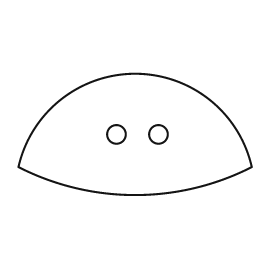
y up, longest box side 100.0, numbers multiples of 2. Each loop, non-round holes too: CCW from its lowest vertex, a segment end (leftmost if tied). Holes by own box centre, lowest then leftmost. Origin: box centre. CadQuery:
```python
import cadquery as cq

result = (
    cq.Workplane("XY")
    .moveTo(-50.0, -14.0)
    .threePointArc((0.0, -26.0), (50.0, -14.0))
    .threePointArc((0.0, 26.0), (-50.0, -14.0))
    .close()
    .moveTo(-8.0, 0.0)
    .circle(4.0)
    .moveTo(10.0, 0.0)
    .circle(4.0)
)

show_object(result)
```